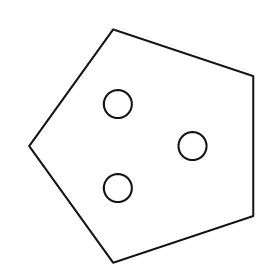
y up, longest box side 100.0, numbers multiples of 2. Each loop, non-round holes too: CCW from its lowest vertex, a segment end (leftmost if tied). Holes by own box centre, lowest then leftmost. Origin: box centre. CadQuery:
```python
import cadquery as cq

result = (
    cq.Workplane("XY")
    .moveTo(-12.0, -50.0)
    .lineTo(48.0, -30.0)
    .lineTo(48.0, 30.0)
    .lineTo(-12.0, 50.0)
    .lineTo(-48.0, 0.0)
    .close()
    .moveTo(-10.0, -18.0)
    .circle(6.0)
    .moveTo(22.0, 0.0)
    .circle(6.0)
    .moveTo(-10.0, 18.0)
    .circle(6.0)
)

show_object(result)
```